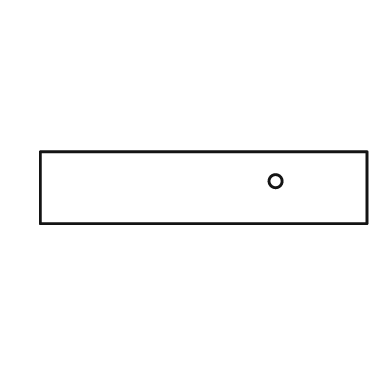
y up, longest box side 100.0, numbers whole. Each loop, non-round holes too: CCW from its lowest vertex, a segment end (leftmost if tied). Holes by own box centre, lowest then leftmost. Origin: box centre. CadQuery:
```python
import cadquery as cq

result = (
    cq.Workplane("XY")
    .moveTo(-50.0, -11.0)
    .lineTo(50.0, -11.0)
    .lineTo(50.0, 11.0)
    .lineTo(-50.0, 11.0)
    .close()
    .moveTo(22.0, 2.0)
    .circle(2.0)
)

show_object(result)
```